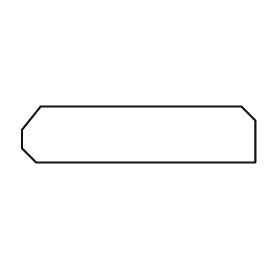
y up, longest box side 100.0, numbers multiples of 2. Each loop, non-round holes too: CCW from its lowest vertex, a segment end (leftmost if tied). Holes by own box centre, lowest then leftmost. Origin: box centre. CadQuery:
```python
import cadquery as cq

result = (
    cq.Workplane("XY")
    .moveTo(-44.0, -12.0)
    .lineTo(50.0, -12.0)
    .lineTo(50.0, 6.0)
    .lineTo(44.0, 12.0)
    .lineTo(-42.0, 12.0)
    .lineTo(-50.0, 2.0)
    .lineTo(-50.0, -6.0)
    .close()
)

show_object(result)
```